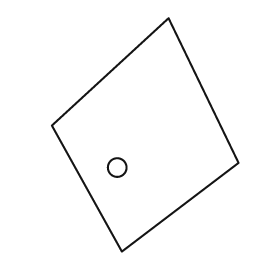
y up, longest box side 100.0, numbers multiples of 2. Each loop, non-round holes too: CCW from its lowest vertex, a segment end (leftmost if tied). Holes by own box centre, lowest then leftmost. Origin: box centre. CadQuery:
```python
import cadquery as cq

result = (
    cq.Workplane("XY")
    .moveTo(-10.0, -50.0)
    .lineTo(40.0, -12.0)
    .lineTo(10.0, 50.0)
    .lineTo(-40.0, 4.0)
    .close()
    .moveTo(-12.0, -14.0)
    .circle(4.0)
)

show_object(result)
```